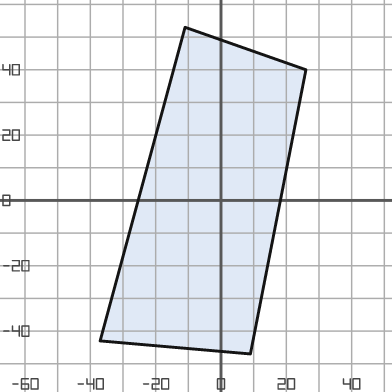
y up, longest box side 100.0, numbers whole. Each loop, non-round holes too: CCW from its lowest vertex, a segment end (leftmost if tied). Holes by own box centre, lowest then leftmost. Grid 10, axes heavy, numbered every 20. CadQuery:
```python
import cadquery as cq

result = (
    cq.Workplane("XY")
    .moveTo(9.0, -47.0)
    .lineTo(26.0, 40.0)
    .lineTo(-11.0, 53.0)
    .lineTo(-37.0, -43.0)
    .close()
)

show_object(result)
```